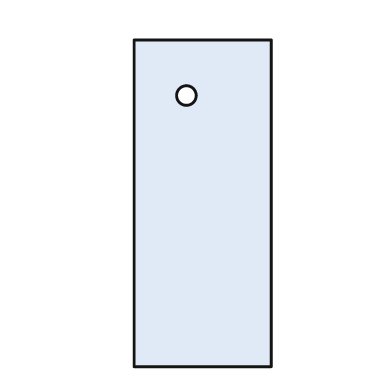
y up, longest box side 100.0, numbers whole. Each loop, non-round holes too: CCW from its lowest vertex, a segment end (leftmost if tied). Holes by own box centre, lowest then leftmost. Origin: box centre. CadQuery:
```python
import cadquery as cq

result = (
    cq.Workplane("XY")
    .moveTo(-21.0, -50.0)
    .lineTo(21.0, -50.0)
    .lineTo(21.0, 50.0)
    .lineTo(-21.0, 50.0)
    .close()
    .moveTo(-5.0, 33.0)
    .circle(3.0)
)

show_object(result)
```